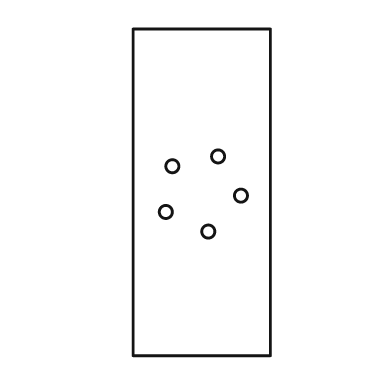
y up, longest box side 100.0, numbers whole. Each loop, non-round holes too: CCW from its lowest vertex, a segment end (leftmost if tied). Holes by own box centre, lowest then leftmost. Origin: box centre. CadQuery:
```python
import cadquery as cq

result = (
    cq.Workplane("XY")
    .moveTo(-21.0, -50.0)
    .lineTo(21.0, -50.0)
    .lineTo(21.0, 50.0)
    .lineTo(-21.0, 50.0)
    .close()
    .moveTo(2.0, -12.0)
    .circle(2.0)
    .moveTo(-11.0, -6.0)
    .circle(2.0)
    .moveTo(12.0, -1.0)
    .circle(2.0)
    .moveTo(-9.0, 8.0)
    .circle(2.0)
    .moveTo(5.0, 11.0)
    .circle(2.0)
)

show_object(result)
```